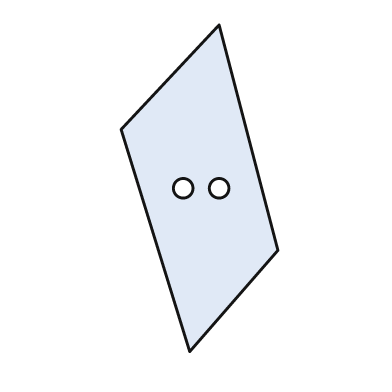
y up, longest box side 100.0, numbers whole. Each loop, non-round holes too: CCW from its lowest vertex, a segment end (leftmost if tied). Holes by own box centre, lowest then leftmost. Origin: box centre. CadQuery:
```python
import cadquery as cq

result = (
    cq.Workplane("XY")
    .moveTo(-3.0, -50.0)
    .lineTo(24.0, -19.0)
    .lineTo(6.0, 50.0)
    .lineTo(-24.0, 18.0)
    .close()
    .moveTo(-5.0, 0.0)
    .circle(3.0)
    .moveTo(6.0, 0.0)
    .circle(3.0)
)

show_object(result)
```